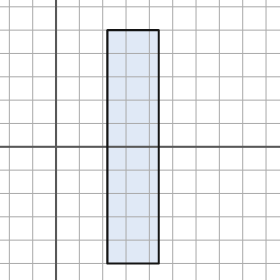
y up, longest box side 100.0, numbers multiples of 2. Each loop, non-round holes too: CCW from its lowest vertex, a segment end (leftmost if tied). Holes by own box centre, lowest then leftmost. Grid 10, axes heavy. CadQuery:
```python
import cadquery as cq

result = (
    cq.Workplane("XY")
    .moveTo(22.0, -50.0)
    .lineTo(44.0, -50.0)
    .lineTo(44.0, 50.0)
    .lineTo(22.0, 50.0)
    .close()
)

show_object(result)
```